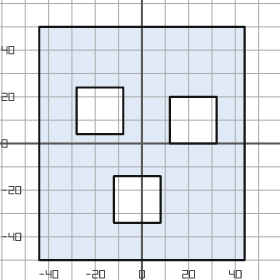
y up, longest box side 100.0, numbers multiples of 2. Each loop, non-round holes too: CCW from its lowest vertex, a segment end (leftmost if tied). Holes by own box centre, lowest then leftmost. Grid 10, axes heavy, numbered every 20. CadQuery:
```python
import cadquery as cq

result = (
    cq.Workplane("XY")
    .moveTo(-44.0, -50.0)
    .lineTo(44.0, -50.0)
    .lineTo(44.0, 50.0)
    .lineTo(-44.0, 50.0)
    .close()
    .moveTo(-12.0, -34.0)
    .lineTo(8.0, -34.0)
    .lineTo(8.0, -14.0)
    .lineTo(-12.0, -14.0)
    .close()
    .moveTo(12.0, 0.0)
    .lineTo(32.0, 0.0)
    .lineTo(32.0, 20.0)
    .lineTo(12.0, 20.0)
    .close()
    .moveTo(-28.0, 4.0)
    .lineTo(-8.0, 4.0)
    .lineTo(-8.0, 24.0)
    .lineTo(-28.0, 24.0)
    .close()
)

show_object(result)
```